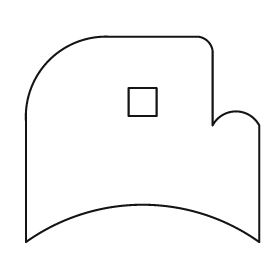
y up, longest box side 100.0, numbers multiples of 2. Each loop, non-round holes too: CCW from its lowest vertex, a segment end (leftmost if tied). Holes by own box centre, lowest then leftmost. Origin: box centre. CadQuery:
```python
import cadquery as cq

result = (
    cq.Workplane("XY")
    .moveTo(-50.0, -44.0)
    .threePointArc((0.0, -28.0), (50.0, -44.0))
    .lineTo(50.0, 6.0)
    .threePointArc((40.0, 12.0), (30.0, 6.0))
    .lineTo(30.0, 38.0)
    .threePointArc((28.0, 42.0), (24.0, 44.0))
    .lineTo(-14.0, 44.0)
    .threePointArc((-40.0, 34.0), (-50.0, 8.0))
    .close()
    .moveTo(-6.0, 10.0)
    .lineTo(6.0, 10.0)
    .lineTo(6.0, 22.0)
    .lineTo(-6.0, 22.0)
    .close()
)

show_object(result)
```